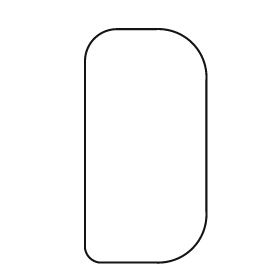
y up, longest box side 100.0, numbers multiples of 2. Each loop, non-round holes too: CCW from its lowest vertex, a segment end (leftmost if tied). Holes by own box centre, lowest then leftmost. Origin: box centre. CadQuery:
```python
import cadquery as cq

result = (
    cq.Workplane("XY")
    .moveTo(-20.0, -50.0)
    .lineTo(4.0, -50.0)
    .threePointArc((20.0, -44.0), (26.0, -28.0))
    .lineTo(26.0, 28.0)
    .threePointArc((20.0, 44.0), (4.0, 50.0))
    .lineTo(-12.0, 50.0)
    .threePointArc((-22.0, 46.0), (-26.0, 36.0))
    .lineTo(-26.0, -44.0)
    .threePointArc((-24.0, -48.0), (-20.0, -50.0))
    .close()
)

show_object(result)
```